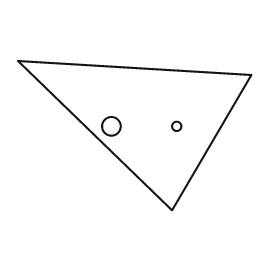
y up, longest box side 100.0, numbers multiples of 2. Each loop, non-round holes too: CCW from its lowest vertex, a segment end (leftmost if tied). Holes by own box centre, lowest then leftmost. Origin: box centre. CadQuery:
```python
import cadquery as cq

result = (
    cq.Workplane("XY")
    .moveTo(16.0, -32.0)
    .lineTo(50.0, 26.0)
    .lineTo(-50.0, 32.0)
    .close()
    .moveTo(-10.0, 4.0)
    .circle(4.0)
    .moveTo(18.0, 4.0)
    .circle(2.0)
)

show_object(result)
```